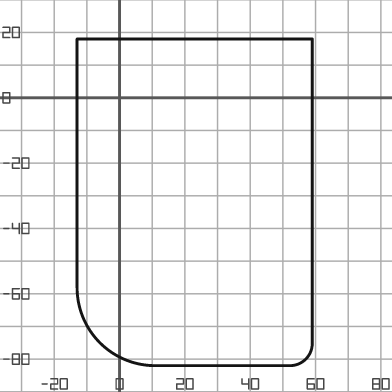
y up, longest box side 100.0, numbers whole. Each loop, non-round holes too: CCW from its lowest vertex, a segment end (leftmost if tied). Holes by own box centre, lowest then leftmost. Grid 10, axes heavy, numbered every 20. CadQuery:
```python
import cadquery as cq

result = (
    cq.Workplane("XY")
    .moveTo(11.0, -82.0)
    .lineTo(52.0, -82.0)
    .threePointArc((57.0, -80.0), (59.0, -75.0))
    .lineTo(59.0, 18.0)
    .lineTo(-13.0, 18.0)
    .lineTo(-13.0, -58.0)
    .threePointArc((-6.0, -75.0), (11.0, -82.0))
    .close()
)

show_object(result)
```